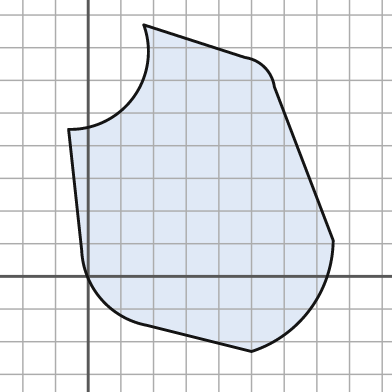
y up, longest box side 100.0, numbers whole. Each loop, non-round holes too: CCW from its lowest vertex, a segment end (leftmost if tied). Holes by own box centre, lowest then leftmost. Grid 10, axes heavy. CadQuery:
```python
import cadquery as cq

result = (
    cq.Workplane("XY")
    .moveTo(50.0, -23.0)
    .threePointArc((68.0, -10.0), (75.0, 11.0))
    .lineTo(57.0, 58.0)
    .threePointArc((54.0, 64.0), (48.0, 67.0))
    .lineTo(17.0, 77.0)
    .threePointArc((14.0, 55.0), (-6.0, 45.0))
    .lineTo(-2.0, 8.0)
    .threePointArc((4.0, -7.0), (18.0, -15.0))
    .close()
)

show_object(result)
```